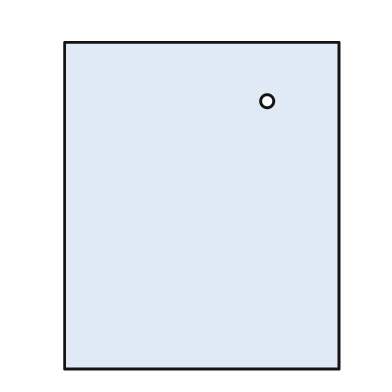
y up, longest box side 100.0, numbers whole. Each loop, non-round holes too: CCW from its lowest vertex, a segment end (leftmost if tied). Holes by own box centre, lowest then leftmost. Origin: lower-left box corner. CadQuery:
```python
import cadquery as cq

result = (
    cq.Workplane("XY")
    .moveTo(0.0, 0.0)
    .lineTo(84.0, 0.0)
    .lineTo(84.0, 100.0)
    .lineTo(0.0, 100.0)
    .close()
    .moveTo(62.0, 82.0)
    .circle(2.0)
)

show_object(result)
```